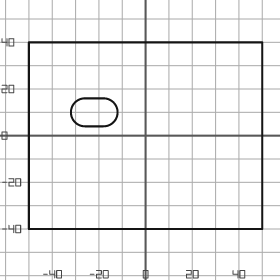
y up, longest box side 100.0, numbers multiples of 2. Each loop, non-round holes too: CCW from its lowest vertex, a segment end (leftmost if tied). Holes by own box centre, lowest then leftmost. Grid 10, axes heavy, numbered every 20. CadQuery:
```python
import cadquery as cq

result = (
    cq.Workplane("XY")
    .moveTo(-50.0, -40.0)
    .lineTo(50.0, -40.0)
    .lineTo(50.0, 40.0)
    .lineTo(-50.0, 40.0)
    .close()
    .moveTo(-26.0, 4.0)
    .lineTo(-18.0, 4.0)
    .threePointArc((-12.0, 10.0), (-18.0, 16.0))
    .lineTo(-26.0, 16.0)
    .threePointArc((-32.0, 10.0), (-26.0, 4.0))
    .close()
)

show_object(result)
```